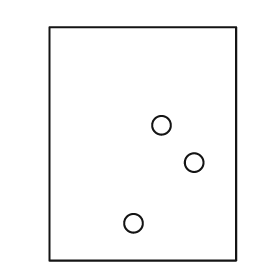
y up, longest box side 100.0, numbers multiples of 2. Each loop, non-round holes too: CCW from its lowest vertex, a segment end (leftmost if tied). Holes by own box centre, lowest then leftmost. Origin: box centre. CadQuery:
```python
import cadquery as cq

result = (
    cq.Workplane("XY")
    .moveTo(-40.0, -50.0)
    .lineTo(40.0, -50.0)
    .lineTo(40.0, 50.0)
    .lineTo(-40.0, 50.0)
    .close()
    .moveTo(-4.0, -34.0)
    .circle(4.0)
    .moveTo(22.0, -8.0)
    .circle(4.0)
    .moveTo(8.0, 8.0)
    .circle(4.0)
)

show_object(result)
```